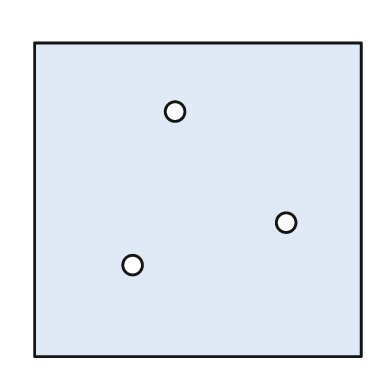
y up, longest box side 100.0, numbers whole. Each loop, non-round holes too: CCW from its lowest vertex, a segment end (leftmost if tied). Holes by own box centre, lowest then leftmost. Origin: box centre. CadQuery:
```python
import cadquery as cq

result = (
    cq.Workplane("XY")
    .moveTo(-50.0, -48.0)
    .lineTo(50.0, -48.0)
    .lineTo(50.0, 48.0)
    .lineTo(-50.0, 48.0)
    .close()
    .moveTo(-20.0, -20.0)
    .circle(3.0)
    .moveTo(27.0, -7.0)
    .circle(3.0)
    .moveTo(-7.0, 27.0)
    .circle(3.0)
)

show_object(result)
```